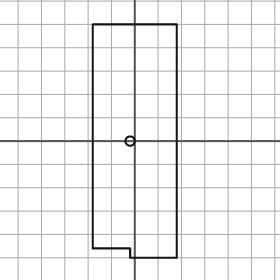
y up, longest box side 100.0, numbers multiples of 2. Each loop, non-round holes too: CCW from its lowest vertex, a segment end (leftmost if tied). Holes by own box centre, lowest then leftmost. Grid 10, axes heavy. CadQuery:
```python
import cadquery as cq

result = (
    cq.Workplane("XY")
    .moveTo(-2.0, -50.0)
    .lineTo(18.0, -50.0)
    .lineTo(18.0, 50.0)
    .lineTo(-18.0, 50.0)
    .lineTo(-18.0, -46.0)
    .lineTo(-2.0, -46.0)
    .close()
    .moveTo(-2.0, 0.0)
    .circle(2.0)
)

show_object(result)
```